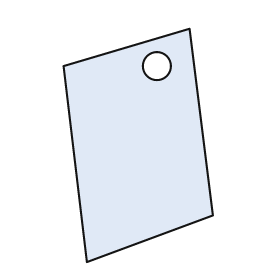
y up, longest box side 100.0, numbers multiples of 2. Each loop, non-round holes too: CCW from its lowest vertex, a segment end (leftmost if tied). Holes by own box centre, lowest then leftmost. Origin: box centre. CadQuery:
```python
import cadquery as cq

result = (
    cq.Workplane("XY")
    .moveTo(-22.0, -50.0)
    .lineTo(32.0, -30.0)
    .lineTo(22.0, 50.0)
    .lineTo(-32.0, 34.0)
    .close()
    .moveTo(8.0, 34.0)
    .circle(6.0)
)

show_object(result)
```